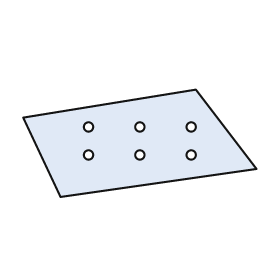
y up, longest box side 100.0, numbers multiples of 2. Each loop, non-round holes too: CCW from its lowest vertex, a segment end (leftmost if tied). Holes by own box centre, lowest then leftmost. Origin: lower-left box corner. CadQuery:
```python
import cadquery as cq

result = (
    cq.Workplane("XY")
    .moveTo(16.0, 0.0)
    .lineTo(100.0, 12.0)
    .lineTo(74.0, 46.0)
    .lineTo(0.0, 34.0)
    .close()
    .moveTo(28.0, 18.0)
    .circle(2.0)
    .moveTo(50.0, 18.0)
    .circle(2.0)
    .moveTo(72.0, 18.0)
    .circle(2.0)
    .moveTo(28.0, 30.0)
    .circle(2.0)
    .moveTo(50.0, 30.0)
    .circle(2.0)
    .moveTo(72.0, 30.0)
    .circle(2.0)
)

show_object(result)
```